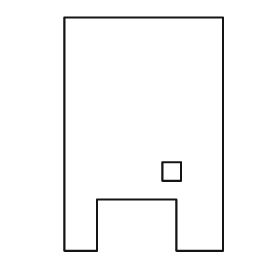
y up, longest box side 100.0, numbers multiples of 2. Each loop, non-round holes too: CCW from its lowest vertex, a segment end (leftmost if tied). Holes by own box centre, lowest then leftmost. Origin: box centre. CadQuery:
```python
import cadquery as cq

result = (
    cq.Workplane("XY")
    .moveTo(-34.0, -50.0)
    .lineTo(-20.0, -50.0)
    .lineTo(-20.0, -28.0)
    .lineTo(14.0, -28.0)
    .lineTo(14.0, -50.0)
    .lineTo(34.0, -50.0)
    .lineTo(34.0, 50.0)
    .lineTo(-34.0, 50.0)
    .close()
    .moveTo(8.0, -20.0)
    .lineTo(16.0, -20.0)
    .lineTo(16.0, -12.0)
    .lineTo(8.0, -12.0)
    .close()
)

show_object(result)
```